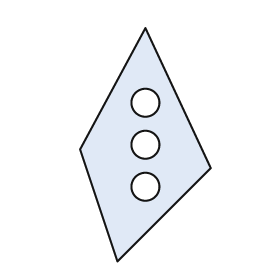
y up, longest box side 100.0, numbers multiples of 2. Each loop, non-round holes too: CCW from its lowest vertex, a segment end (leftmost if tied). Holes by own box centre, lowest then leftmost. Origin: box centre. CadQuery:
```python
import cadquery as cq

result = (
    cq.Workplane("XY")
    .moveTo(-12.0, -50.0)
    .lineTo(28.0, -10.0)
    .lineTo(0.0, 50.0)
    .lineTo(-28.0, -2.0)
    .close()
    .moveTo(0.0, -18.0)
    .circle(6.0)
    .moveTo(0.0, 0.0)
    .circle(6.0)
    .moveTo(0.0, 18.0)
    .circle(6.0)
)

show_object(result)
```